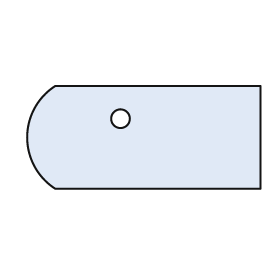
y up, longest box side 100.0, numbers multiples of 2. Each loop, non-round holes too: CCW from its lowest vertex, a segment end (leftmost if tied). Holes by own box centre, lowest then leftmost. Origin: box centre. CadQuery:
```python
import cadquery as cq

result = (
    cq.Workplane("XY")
    .moveTo(-38.0, -22.0)
    .lineTo(50.0, -22.0)
    .lineTo(50.0, 22.0)
    .lineTo(-38.0, 22.0)
    .threePointArc((-50.0, 0.0), (-38.0, -22.0))
    .close()
    .moveTo(-10.0, 8.0)
    .circle(4.0)
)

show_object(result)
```